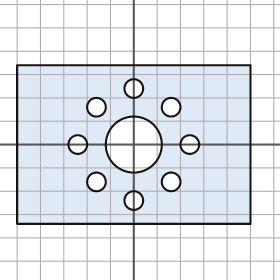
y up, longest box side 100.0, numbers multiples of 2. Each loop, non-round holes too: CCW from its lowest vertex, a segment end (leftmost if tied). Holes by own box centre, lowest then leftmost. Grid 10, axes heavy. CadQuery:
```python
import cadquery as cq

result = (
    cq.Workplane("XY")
    .moveTo(-50.0, -34.0)
    .lineTo(50.0, -34.0)
    .lineTo(50.0, 34.0)
    .lineTo(-50.0, 34.0)
    .close()
    .moveTo(0.0, -24.0)
    .circle(4.0)
    .moveTo(-16.0, -16.0)
    .circle(4.0)
    .moveTo(16.0, -16.0)
    .circle(4.0)
    .moveTo(-24.0, 0.0)
    .circle(4.0)
    .moveTo(0.0, 0.0)
    .circle(12.0)
    .moveTo(24.0, 0.0)
    .circle(4.0)
    .moveTo(-16.0, 16.0)
    .circle(4.0)
    .moveTo(16.0, 16.0)
    .circle(4.0)
    .moveTo(0.0, 24.0)
    .circle(4.0)
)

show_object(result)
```